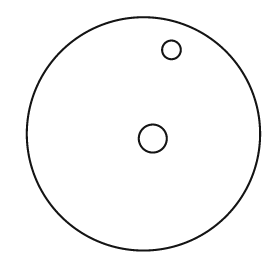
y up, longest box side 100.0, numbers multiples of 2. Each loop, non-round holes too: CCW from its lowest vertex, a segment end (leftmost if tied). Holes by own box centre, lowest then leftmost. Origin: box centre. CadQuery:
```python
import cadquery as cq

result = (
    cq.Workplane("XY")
    .moveTo(0.0, 0.0)
    .circle(50.0)
    .moveTo(4.0, -2.0)
    .circle(6.0)
    .moveTo(12.0, 36.0)
    .circle(4.0)
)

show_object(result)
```